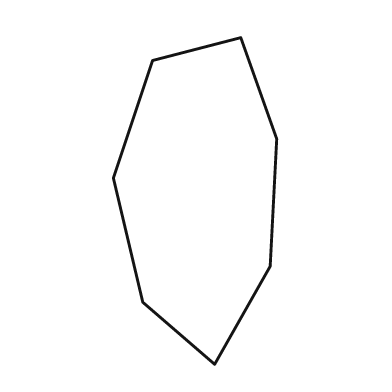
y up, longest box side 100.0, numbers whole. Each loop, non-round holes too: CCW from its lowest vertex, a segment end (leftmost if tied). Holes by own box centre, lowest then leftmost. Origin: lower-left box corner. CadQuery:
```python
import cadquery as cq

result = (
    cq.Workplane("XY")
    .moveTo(31.0, 0.0)
    .lineTo(48.0, 30.0)
    .lineTo(50.0, 69.0)
    .lineTo(39.0, 100.0)
    .lineTo(12.0, 93.0)
    .lineTo(0.0, 57.0)
    .lineTo(9.0, 19.0)
    .close()
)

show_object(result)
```